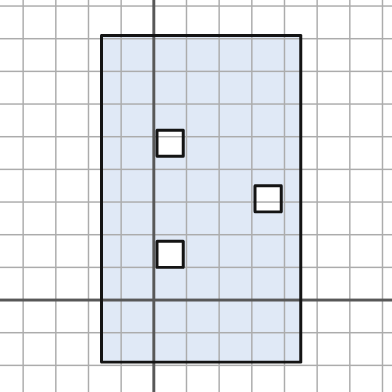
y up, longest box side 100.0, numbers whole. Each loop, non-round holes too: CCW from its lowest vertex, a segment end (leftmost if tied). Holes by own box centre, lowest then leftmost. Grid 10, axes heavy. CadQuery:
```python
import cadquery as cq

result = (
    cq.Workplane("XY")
    .moveTo(-16.0, -19.0)
    .lineTo(45.0, -19.0)
    .lineTo(45.0, 81.0)
    .lineTo(-16.0, 81.0)
    .close()
    .moveTo(1.0, 10.0)
    .lineTo(9.0, 10.0)
    .lineTo(9.0, 18.0)
    .lineTo(1.0, 18.0)
    .close()
    .moveTo(31.0, 27.0)
    .lineTo(39.0, 27.0)
    .lineTo(39.0, 35.0)
    .lineTo(31.0, 35.0)
    .close()
    .moveTo(1.0, 44.0)
    .lineTo(9.0, 44.0)
    .lineTo(9.0, 52.0)
    .lineTo(1.0, 52.0)
    .close()
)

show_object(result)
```